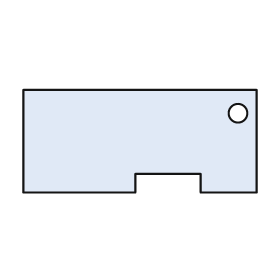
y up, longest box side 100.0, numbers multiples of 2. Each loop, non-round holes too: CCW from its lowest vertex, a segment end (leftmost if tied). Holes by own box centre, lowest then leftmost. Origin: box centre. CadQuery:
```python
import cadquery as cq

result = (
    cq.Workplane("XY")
    .moveTo(-50.0, -22.0)
    .lineTo(-2.0, -22.0)
    .lineTo(-2.0, -14.0)
    .lineTo(26.0, -14.0)
    .lineTo(26.0, -22.0)
    .lineTo(50.0, -22.0)
    .lineTo(50.0, 22.0)
    .lineTo(-50.0, 22.0)
    .close()
    .moveTo(42.0, 12.0)
    .circle(4.0)
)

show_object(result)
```